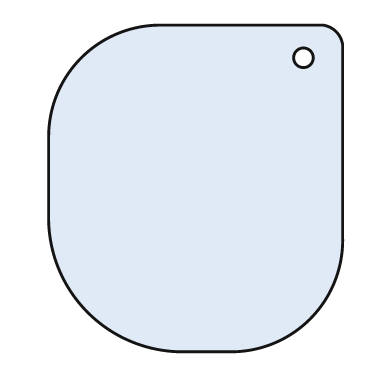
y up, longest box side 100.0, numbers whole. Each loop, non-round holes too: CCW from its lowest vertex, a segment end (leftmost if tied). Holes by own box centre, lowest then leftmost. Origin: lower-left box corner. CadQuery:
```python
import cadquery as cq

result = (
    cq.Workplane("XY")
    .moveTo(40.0, 0.0)
    .lineTo(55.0, 0.0)
    .threePointArc((80.0, 10.0), (90.0, 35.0))
    .lineTo(90.0, 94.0)
    .threePointArc((88.0, 98.0), (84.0, 100.0))
    .lineTo(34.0, 100.0)
    .threePointArc((10.0, 90.0), (0.0, 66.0))
    .lineTo(0.0, 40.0)
    .threePointArc((12.0, 12.0), (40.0, 0.0))
    .close()
    .moveTo(78.0, 90.0)
    .circle(3.0)
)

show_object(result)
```